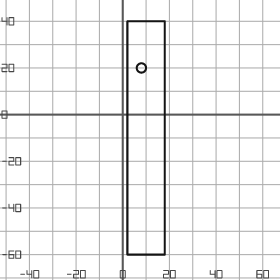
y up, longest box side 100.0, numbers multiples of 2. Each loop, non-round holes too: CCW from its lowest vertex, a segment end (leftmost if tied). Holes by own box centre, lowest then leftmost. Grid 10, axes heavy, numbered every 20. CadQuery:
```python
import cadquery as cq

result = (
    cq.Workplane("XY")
    .moveTo(2.0, -60.0)
    .lineTo(18.0, -60.0)
    .lineTo(18.0, 40.0)
    .lineTo(2.0, 40.0)
    .close()
    .moveTo(8.0, 20.0)
    .circle(2.0)
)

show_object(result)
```